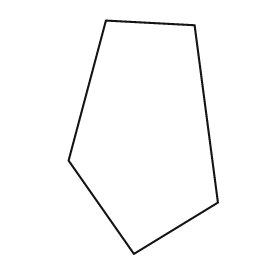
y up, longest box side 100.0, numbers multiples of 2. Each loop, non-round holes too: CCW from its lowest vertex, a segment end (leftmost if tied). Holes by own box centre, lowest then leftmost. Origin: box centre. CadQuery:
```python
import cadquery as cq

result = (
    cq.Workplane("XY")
    .moveTo(-4.0, -50.0)
    .lineTo(32.0, -28.0)
    .lineTo(22.0, 48.0)
    .lineTo(-16.0, 50.0)
    .lineTo(-32.0, -10.0)
    .close()
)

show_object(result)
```